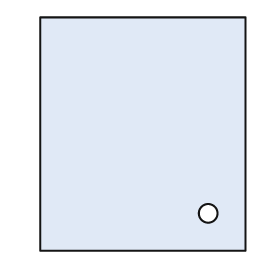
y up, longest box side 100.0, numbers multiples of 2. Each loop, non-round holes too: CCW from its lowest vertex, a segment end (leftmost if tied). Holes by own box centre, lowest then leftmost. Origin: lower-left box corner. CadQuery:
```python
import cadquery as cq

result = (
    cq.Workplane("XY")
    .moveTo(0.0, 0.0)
    .lineTo(88.0, 0.0)
    .lineTo(88.0, 100.0)
    .lineTo(0.0, 100.0)
    .close()
    .moveTo(72.0, 16.0)
    .circle(4.0)
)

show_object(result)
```